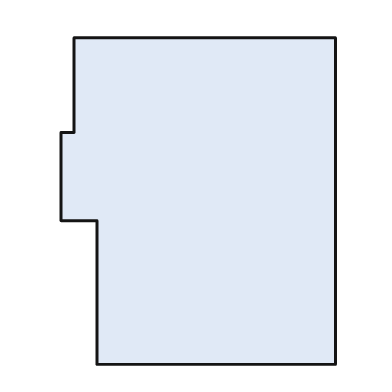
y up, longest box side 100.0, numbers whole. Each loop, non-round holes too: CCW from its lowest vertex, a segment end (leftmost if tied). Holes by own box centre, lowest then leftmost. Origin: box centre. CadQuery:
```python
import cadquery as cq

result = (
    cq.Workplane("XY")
    .moveTo(-31.0, -50.0)
    .lineTo(42.0, -50.0)
    .lineTo(42.0, 50.0)
    .lineTo(-38.0, 50.0)
    .lineTo(-38.0, 21.0)
    .lineTo(-42.0, 21.0)
    .lineTo(-42.0, -6.0)
    .lineTo(-31.0, -6.0)
    .close()
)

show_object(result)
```